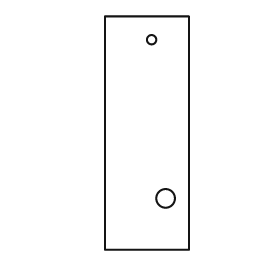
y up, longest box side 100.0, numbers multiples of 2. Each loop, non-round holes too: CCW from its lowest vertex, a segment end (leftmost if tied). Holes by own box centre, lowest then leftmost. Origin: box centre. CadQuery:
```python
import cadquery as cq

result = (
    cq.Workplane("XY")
    .moveTo(-18.0, -50.0)
    .lineTo(18.0, -50.0)
    .lineTo(18.0, 50.0)
    .lineTo(-18.0, 50.0)
    .close()
    .moveTo(8.0, -28.0)
    .circle(4.0)
    .moveTo(2.0, 40.0)
    .circle(2.0)
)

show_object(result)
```